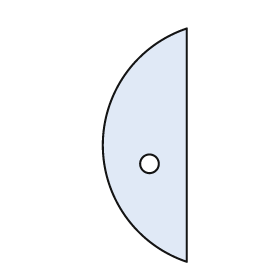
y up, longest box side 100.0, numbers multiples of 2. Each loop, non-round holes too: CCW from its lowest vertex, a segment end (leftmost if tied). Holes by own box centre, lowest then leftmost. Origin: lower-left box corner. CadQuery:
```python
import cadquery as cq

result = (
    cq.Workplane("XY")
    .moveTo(36.0, 0.0)
    .lineTo(36.0, 100.0)
    .threePointArc((0.0, 50.0), (36.0, 0.0))
    .close()
    .moveTo(20.0, 42.0)
    .circle(4.0)
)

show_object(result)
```